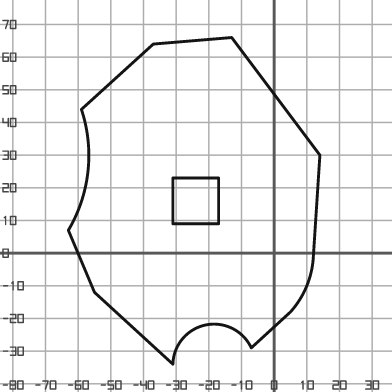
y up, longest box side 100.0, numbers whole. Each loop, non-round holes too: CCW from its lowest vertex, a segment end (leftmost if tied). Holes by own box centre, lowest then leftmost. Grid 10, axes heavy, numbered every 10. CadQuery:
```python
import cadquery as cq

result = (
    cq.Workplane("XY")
    .moveTo(-31.0, -34.0)
    .threePointArc((-21.0, -22.0), (-7.0, -29.0))
    .lineTo(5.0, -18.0)
    .threePointArc((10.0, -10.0), (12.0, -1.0))
    .lineTo(14.0, 30.0)
    .lineTo(-13.0, 66.0)
    .lineTo(-37.0, 64.0)
    .lineTo(-59.0, 44.0)
    .threePointArc((-57.0, 25.0), (-63.0, 7.0))
    .lineTo(-55.0, -12.0)
    .close()
    .moveTo(-31.0, 9.0)
    .lineTo(-17.0, 9.0)
    .lineTo(-17.0, 23.0)
    .lineTo(-31.0, 23.0)
    .close()
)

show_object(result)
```